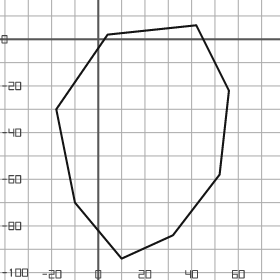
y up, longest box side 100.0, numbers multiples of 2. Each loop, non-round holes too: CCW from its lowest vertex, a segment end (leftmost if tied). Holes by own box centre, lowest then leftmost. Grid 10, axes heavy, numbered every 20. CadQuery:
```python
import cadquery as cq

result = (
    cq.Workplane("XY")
    .moveTo(10.0, -94.0)
    .lineTo(32.0, -84.0)
    .lineTo(52.0, -58.0)
    .lineTo(56.0, -22.0)
    .lineTo(42.0, 6.0)
    .lineTo(4.0, 2.0)
    .lineTo(-18.0, -30.0)
    .lineTo(-10.0, -70.0)
    .close()
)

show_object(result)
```